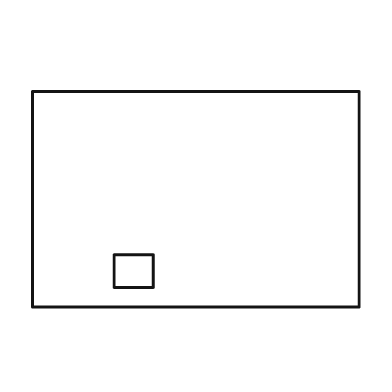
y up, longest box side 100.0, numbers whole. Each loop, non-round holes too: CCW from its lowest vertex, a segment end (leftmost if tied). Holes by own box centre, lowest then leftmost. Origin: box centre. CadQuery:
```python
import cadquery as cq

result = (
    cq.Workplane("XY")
    .moveTo(-50.0, -33.0)
    .lineTo(50.0, -33.0)
    .lineTo(50.0, 33.0)
    .lineTo(-50.0, 33.0)
    .close()
    .moveTo(-25.0, -27.0)
    .lineTo(-13.0, -27.0)
    .lineTo(-13.0, -17.0)
    .lineTo(-25.0, -17.0)
    .close()
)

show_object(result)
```